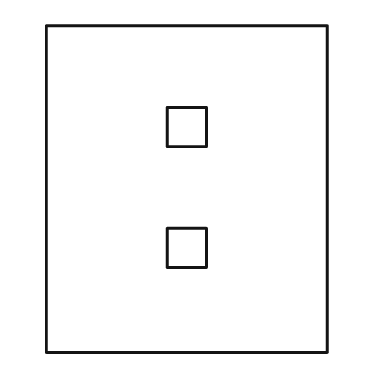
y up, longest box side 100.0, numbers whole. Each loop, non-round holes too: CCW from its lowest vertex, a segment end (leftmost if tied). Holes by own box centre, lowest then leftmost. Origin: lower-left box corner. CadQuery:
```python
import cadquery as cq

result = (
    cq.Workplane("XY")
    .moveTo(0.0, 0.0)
    .lineTo(86.0, 0.0)
    .lineTo(86.0, 100.0)
    .lineTo(0.0, 100.0)
    .close()
    .moveTo(37.0, 26.0)
    .lineTo(49.0, 26.0)
    .lineTo(49.0, 38.0)
    .lineTo(37.0, 38.0)
    .close()
    .moveTo(37.0, 63.0)
    .lineTo(49.0, 63.0)
    .lineTo(49.0, 75.0)
    .lineTo(37.0, 75.0)
    .close()
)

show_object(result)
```